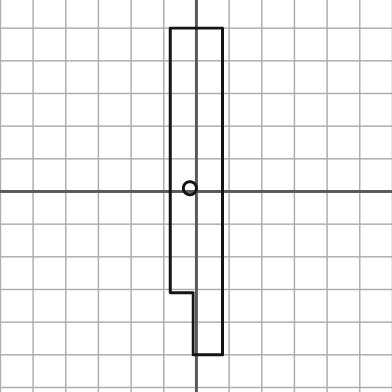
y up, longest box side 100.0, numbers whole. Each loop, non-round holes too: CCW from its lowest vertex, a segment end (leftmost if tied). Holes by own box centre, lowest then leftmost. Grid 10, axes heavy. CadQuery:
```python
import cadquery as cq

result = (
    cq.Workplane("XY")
    .moveTo(-1.0, -50.0)
    .lineTo(8.0, -50.0)
    .lineTo(8.0, 50.0)
    .lineTo(-8.0, 50.0)
    .lineTo(-8.0, -31.0)
    .lineTo(-1.0, -31.0)
    .close()
    .moveTo(-2.0, 1.0)
    .circle(2.0)
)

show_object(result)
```